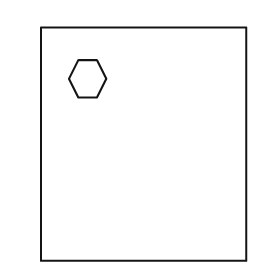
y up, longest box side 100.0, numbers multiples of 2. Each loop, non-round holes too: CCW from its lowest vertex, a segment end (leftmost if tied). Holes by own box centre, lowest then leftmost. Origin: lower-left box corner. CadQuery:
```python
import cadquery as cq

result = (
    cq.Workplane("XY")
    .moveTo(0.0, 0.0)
    .lineTo(88.0, 0.0)
    .lineTo(88.0, 100.0)
    .lineTo(0.0, 100.0)
    .close()
    .moveTo(16.0, 70.0)
    .lineTo(24.0, 70.0)
    .lineTo(28.0, 78.0)
    .lineTo(24.0, 86.0)
    .lineTo(16.0, 86.0)
    .lineTo(12.0, 78.0)
    .close()
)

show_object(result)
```